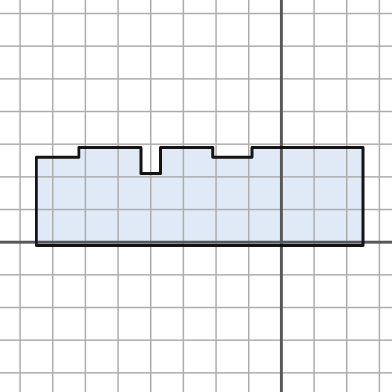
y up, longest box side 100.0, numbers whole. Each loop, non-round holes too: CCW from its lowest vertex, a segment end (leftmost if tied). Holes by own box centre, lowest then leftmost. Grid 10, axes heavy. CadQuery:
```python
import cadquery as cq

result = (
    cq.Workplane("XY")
    .moveTo(-75.0, -1.0)
    .lineTo(25.0, -1.0)
    .lineTo(25.0, 29.0)
    .lineTo(-9.0, 29.0)
    .lineTo(-9.0, 26.0)
    .lineTo(-21.0, 26.0)
    .lineTo(-21.0, 29.0)
    .lineTo(-37.0, 29.0)
    .lineTo(-37.0, 21.0)
    .lineTo(-43.0, 21.0)
    .lineTo(-43.0, 29.0)
    .lineTo(-62.0, 29.0)
    .lineTo(-62.0, 26.0)
    .lineTo(-75.0, 26.0)
    .close()
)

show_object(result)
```